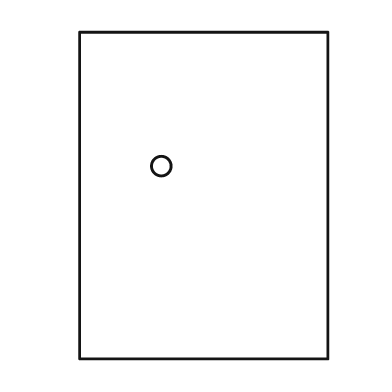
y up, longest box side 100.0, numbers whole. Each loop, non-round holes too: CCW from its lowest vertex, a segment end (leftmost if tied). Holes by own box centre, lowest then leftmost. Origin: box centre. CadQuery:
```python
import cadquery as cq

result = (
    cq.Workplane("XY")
    .moveTo(-38.0, -50.0)
    .lineTo(38.0, -50.0)
    .lineTo(38.0, 50.0)
    .lineTo(-38.0, 50.0)
    .close()
    .moveTo(-13.0, 9.0)
    .circle(3.0)
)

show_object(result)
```